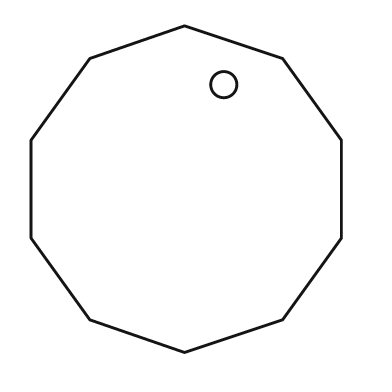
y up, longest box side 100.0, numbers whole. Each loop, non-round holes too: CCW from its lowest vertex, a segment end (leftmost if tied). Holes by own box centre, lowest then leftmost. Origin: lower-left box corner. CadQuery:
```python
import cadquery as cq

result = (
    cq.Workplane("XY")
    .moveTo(47.0, 0.0)
    .lineTo(77.0, 10.0)
    .lineTo(95.0, 35.0)
    .lineTo(95.0, 65.0)
    .lineTo(77.0, 90.0)
    .lineTo(47.0, 100.0)
    .lineTo(18.0, 90.0)
    .lineTo(0.0, 65.0)
    .lineTo(0.0, 35.0)
    .lineTo(18.0, 10.0)
    .close()
    .moveTo(59.0, 82.0)
    .circle(4.0)
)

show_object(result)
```